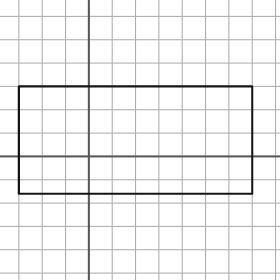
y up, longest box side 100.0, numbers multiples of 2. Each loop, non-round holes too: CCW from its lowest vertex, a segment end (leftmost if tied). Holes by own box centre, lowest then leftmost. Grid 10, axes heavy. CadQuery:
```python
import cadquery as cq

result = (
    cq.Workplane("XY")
    .moveTo(-30.0, -16.0)
    .lineTo(70.0, -16.0)
    .lineTo(70.0, 30.0)
    .lineTo(-30.0, 30.0)
    .close()
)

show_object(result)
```